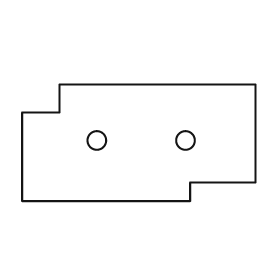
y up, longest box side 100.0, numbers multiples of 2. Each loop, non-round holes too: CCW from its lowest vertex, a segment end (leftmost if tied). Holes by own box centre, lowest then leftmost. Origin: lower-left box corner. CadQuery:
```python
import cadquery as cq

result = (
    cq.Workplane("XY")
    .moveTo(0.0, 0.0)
    .lineTo(72.0, 0.0)
    .lineTo(72.0, 8.0)
    .lineTo(100.0, 8.0)
    .lineTo(100.0, 50.0)
    .lineTo(16.0, 50.0)
    .lineTo(16.0, 38.0)
    .lineTo(0.0, 38.0)
    .close()
    .moveTo(32.0, 26.0)
    .circle(4.0)
    .moveTo(70.0, 26.0)
    .circle(4.0)
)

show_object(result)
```